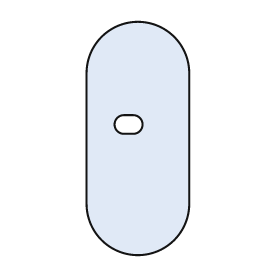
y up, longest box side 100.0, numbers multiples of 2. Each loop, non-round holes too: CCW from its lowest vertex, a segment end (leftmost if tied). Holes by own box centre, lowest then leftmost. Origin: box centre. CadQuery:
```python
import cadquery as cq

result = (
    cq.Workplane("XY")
    .moveTo(-22.0, -28.0)
    .threePointArc((0.0, -50.0), (22.0, -28.0))
    .lineTo(22.0, 28.0)
    .threePointArc((0.0, 50.0), (-22.0, 28.0))
    .close()
    .moveTo(-6.0, 2.0)
    .lineTo(-2.0, 2.0)
    .threePointArc((2.0, 6.0), (-2.0, 10.0))
    .lineTo(-6.0, 10.0)
    .threePointArc((-10.0, 6.0), (-6.0, 2.0))
    .close()
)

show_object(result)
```